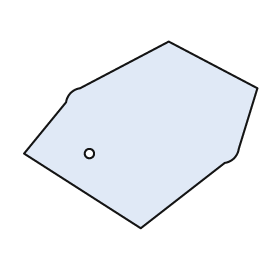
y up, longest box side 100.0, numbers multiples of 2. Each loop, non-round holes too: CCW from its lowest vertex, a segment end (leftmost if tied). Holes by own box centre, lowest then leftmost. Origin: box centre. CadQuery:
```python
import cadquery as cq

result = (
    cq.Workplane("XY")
    .moveTo(0.0, -40.0)
    .lineTo(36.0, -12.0)
    .threePointArc((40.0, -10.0), (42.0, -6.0))
    .lineTo(50.0, 20.0)
    .lineTo(12.0, 40.0)
    .lineTo(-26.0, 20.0)
    .threePointArc((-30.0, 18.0), (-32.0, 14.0))
    .lineTo(-50.0, -8.0)
    .close()
    .moveTo(-22.0, -8.0)
    .circle(2.0)
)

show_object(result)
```